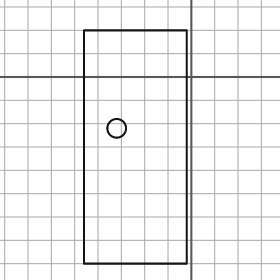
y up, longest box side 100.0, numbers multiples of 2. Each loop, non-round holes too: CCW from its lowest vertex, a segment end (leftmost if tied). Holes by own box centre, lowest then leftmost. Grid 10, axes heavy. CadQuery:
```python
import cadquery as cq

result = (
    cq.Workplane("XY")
    .moveTo(-46.0, -80.0)
    .lineTo(-2.0, -80.0)
    .lineTo(-2.0, 20.0)
    .lineTo(-46.0, 20.0)
    .close()
    .moveTo(-32.0, -22.0)
    .circle(4.0)
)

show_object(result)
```